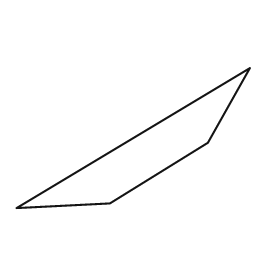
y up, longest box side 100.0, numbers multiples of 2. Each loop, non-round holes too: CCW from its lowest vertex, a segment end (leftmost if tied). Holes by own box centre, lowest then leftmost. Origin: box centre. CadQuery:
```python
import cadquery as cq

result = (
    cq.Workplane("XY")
    .moveTo(-50.0, -30.0)
    .lineTo(-10.0, -28.0)
    .lineTo(32.0, -2.0)
    .lineTo(50.0, 30.0)
    .close()
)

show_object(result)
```